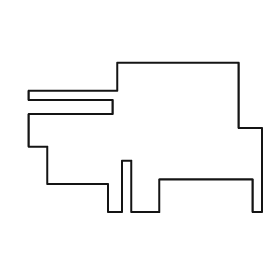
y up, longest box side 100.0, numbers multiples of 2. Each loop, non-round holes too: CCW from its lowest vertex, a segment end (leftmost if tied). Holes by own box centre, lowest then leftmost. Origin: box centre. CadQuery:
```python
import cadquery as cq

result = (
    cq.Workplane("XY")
    .moveTo(-16.0, -32.0)
    .lineTo(-10.0, -32.0)
    .lineTo(-10.0, -10.0)
    .lineTo(-6.0, -10.0)
    .lineTo(-6.0, -32.0)
    .lineTo(6.0, -32.0)
    .lineTo(6.0, -18.0)
    .lineTo(46.0, -18.0)
    .lineTo(46.0, -32.0)
    .lineTo(50.0, -32.0)
    .lineTo(50.0, 4.0)
    .lineTo(40.0, 4.0)
    .lineTo(40.0, 32.0)
    .lineTo(-12.0, 32.0)
    .lineTo(-12.0, 20.0)
    .lineTo(-50.0, 20.0)
    .lineTo(-50.0, 16.0)
    .lineTo(-14.0, 16.0)
    .lineTo(-14.0, 10.0)
    .lineTo(-50.0, 10.0)
    .lineTo(-50.0, -4.0)
    .lineTo(-42.0, -4.0)
    .lineTo(-42.0, -20.0)
    .lineTo(-16.0, -20.0)
    .close()
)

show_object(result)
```